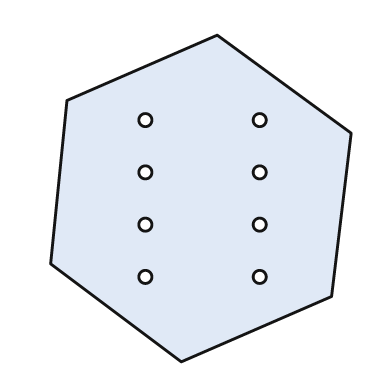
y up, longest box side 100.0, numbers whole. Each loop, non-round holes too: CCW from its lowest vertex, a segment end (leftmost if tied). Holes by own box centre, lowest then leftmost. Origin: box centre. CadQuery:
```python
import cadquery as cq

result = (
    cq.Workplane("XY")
    .moveTo(-6.0, -50.0)
    .lineTo(40.0, -30.0)
    .lineTo(46.0, 20.0)
    .lineTo(5.0, 50.0)
    .lineTo(-41.0, 30.0)
    .lineTo(-46.0, -20.0)
    .close()
    .moveTo(-17.0, -24.0)
    .circle(2.0)
    .moveTo(18.0, -24.0)
    .circle(2.0)
    .moveTo(-17.0, -8.0)
    .circle(2.0)
    .moveTo(18.0, -8.0)
    .circle(2.0)
    .moveTo(-17.0, 8.0)
    .circle(2.0)
    .moveTo(18.0, 8.0)
    .circle(2.0)
    .moveTo(-17.0, 24.0)
    .circle(2.0)
    .moveTo(18.0, 24.0)
    .circle(2.0)
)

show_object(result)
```